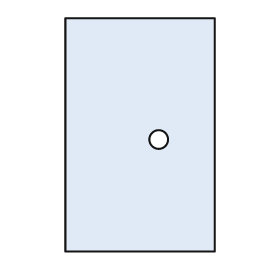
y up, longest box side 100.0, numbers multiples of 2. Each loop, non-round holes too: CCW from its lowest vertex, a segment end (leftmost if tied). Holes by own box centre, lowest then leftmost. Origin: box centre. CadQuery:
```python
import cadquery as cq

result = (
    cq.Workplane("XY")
    .moveTo(-32.0, -50.0)
    .lineTo(32.0, -50.0)
    .lineTo(32.0, 50.0)
    .lineTo(-32.0, 50.0)
    .close()
    .moveTo(8.0, -2.0)
    .circle(4.0)
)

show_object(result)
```